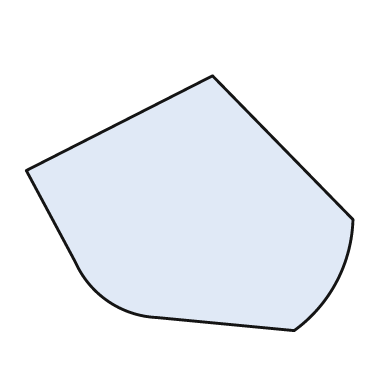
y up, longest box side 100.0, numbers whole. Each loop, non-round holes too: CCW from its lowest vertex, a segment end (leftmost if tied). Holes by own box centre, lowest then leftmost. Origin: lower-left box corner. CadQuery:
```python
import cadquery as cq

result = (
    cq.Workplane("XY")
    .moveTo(82.0, 0.0)
    .threePointArc((95.0, 15.0), (100.0, 34.0))
    .lineTo(57.0, 78.0)
    .lineTo(0.0, 49.0)
    .lineTo(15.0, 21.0)
    .threePointArc((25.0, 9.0), (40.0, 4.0))
    .close()
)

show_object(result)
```